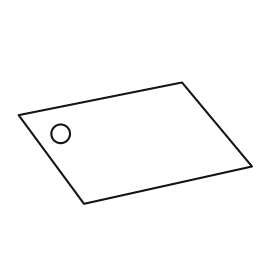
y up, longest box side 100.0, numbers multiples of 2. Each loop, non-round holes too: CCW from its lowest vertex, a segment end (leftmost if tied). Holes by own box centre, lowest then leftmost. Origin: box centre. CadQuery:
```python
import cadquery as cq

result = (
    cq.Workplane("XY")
    .moveTo(-22.0, -26.0)
    .lineTo(50.0, -10.0)
    .lineTo(20.0, 26.0)
    .lineTo(-50.0, 12.0)
    .close()
    .moveTo(-32.0, 4.0)
    .circle(4.0)
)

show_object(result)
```